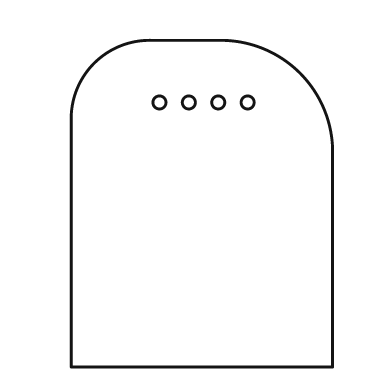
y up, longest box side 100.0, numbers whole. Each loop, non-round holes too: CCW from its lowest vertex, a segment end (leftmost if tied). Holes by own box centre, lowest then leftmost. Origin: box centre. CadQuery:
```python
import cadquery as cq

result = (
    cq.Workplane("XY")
    .moveTo(-40.0, -50.0)
    .lineTo(40.0, -50.0)
    .lineTo(40.0, 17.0)
    .threePointArc((30.0, 40.0), (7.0, 50.0))
    .lineTo(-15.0, 50.0)
    .threePointArc((-33.0, 43.0), (-40.0, 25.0))
    .close()
    .moveTo(-13.0, 31.0)
    .circle(2.0)
    .moveTo(-4.0, 31.0)
    .circle(2.0)
    .moveTo(5.0, 31.0)
    .circle(2.0)
    .moveTo(14.0, 31.0)
    .circle(2.0)
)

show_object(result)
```